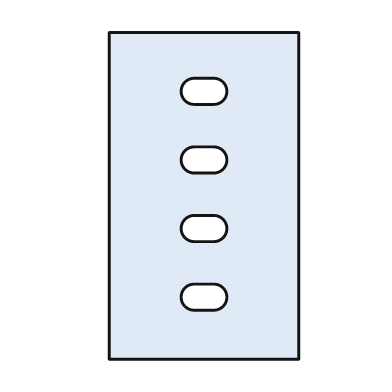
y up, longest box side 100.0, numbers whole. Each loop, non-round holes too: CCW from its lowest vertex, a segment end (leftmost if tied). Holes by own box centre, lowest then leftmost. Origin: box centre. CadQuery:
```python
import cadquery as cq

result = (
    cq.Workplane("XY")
    .moveTo(-29.0, -50.0)
    .lineTo(29.0, -50.0)
    .lineTo(29.0, 50.0)
    .lineTo(-29.0, 50.0)
    .close()
    .moveTo(-3.0, -35.0)
    .lineTo(3.0, -35.0)
    .threePointArc((7.0, -31.0), (3.0, -27.0))
    .lineTo(-3.0, -27.0)
    .threePointArc((-7.0, -31.0), (-3.0, -35.0))
    .close()
    .moveTo(-3.0, -14.0)
    .lineTo(3.0, -14.0)
    .threePointArc((7.0, -10.0), (3.0, -6.0))
    .lineTo(-3.0, -6.0)
    .threePointArc((-7.0, -10.0), (-3.0, -14.0))
    .close()
    .moveTo(-3.0, 7.0)
    .lineTo(3.0, 7.0)
    .threePointArc((7.0, 11.0), (3.0, 15.0))
    .lineTo(-3.0, 15.0)
    .threePointArc((-7.0, 11.0), (-3.0, 7.0))
    .close()
    .moveTo(-3.0, 28.0)
    .lineTo(3.0, 28.0)
    .threePointArc((7.0, 32.0), (3.0, 36.0))
    .lineTo(-3.0, 36.0)
    .threePointArc((-7.0, 32.0), (-3.0, 28.0))
    .close()
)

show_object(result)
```